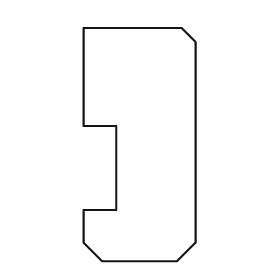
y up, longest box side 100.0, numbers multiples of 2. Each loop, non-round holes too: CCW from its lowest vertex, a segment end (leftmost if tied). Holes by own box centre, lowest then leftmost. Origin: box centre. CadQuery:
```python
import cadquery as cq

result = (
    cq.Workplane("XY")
    .moveTo(-16.0, -50.0)
    .lineTo(16.0, -50.0)
    .lineTo(24.0, -42.0)
    .lineTo(24.0, 44.0)
    .lineTo(18.0, 50.0)
    .lineTo(-24.0, 50.0)
    .lineTo(-24.0, 8.0)
    .lineTo(-10.0, 8.0)
    .lineTo(-10.0, -28.0)
    .lineTo(-24.0, -28.0)
    .lineTo(-24.0, -42.0)
    .close()
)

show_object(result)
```